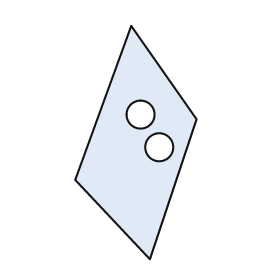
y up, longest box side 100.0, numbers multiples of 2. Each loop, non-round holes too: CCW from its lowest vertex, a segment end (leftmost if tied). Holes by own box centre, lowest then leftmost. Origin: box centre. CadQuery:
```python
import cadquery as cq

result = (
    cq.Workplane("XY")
    .moveTo(6.0, -50.0)
    .lineTo(26.0, 10.0)
    .lineTo(-2.0, 50.0)
    .lineTo(-26.0, -16.0)
    .close()
    .moveTo(10.0, -2.0)
    .circle(6.0)
    .moveTo(2.0, 12.0)
    .circle(6.0)
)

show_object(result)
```